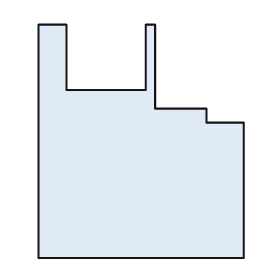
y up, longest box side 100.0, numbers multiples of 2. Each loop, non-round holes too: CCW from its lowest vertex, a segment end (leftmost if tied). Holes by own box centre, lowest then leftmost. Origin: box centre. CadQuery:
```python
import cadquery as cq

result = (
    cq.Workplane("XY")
    .moveTo(-44.0, -50.0)
    .lineTo(44.0, -50.0)
    .lineTo(44.0, 8.0)
    .lineTo(28.0, 8.0)
    .lineTo(28.0, 14.0)
    .lineTo(6.0, 14.0)
    .lineTo(6.0, 50.0)
    .lineTo(2.0, 50.0)
    .lineTo(2.0, 22.0)
    .lineTo(-32.0, 22.0)
    .lineTo(-32.0, 50.0)
    .lineTo(-44.0, 50.0)
    .close()
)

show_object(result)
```